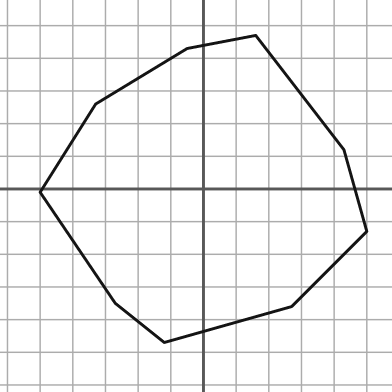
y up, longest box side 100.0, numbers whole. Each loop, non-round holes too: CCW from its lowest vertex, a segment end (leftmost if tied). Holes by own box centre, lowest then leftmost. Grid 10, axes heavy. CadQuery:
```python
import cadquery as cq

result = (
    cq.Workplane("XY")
    .moveTo(-12.0, -47.0)
    .lineTo(27.0, -36.0)
    .lineTo(50.0, -13.0)
    .lineTo(43.0, 12.0)
    .lineTo(16.0, 47.0)
    .lineTo(-5.0, 43.0)
    .lineTo(-33.0, 26.0)
    .lineTo(-50.0, -1.0)
    .lineTo(-27.0, -35.0)
    .close()
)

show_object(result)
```